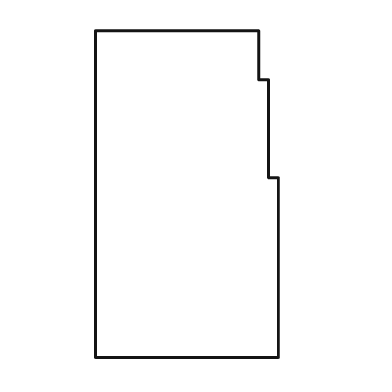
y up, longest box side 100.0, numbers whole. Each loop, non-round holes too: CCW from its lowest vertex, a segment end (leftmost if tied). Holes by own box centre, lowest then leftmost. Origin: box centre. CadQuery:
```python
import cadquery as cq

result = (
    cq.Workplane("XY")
    .moveTo(-28.0, -50.0)
    .lineTo(28.0, -50.0)
    .lineTo(28.0, 5.0)
    .lineTo(25.0, 5.0)
    .lineTo(25.0, 35.0)
    .lineTo(22.0, 35.0)
    .lineTo(22.0, 50.0)
    .lineTo(-28.0, 50.0)
    .close()
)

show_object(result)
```